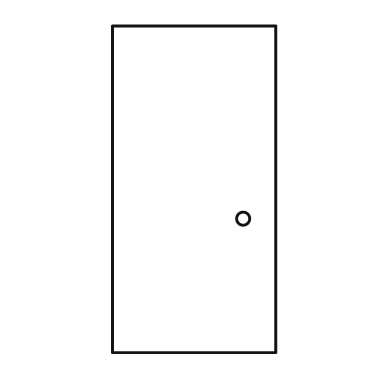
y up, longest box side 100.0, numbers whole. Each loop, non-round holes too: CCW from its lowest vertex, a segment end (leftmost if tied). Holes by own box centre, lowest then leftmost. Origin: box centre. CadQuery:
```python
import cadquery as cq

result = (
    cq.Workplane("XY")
    .moveTo(-25.0, -50.0)
    .lineTo(25.0, -50.0)
    .lineTo(25.0, 50.0)
    .lineTo(-25.0, 50.0)
    .close()
    .moveTo(15.0, -9.0)
    .circle(2.0)
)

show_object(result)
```